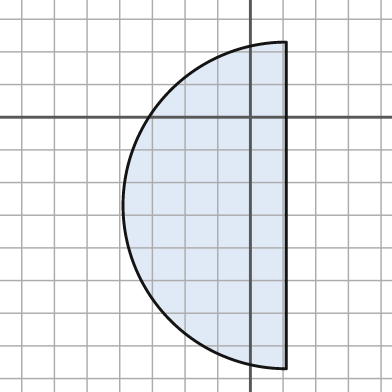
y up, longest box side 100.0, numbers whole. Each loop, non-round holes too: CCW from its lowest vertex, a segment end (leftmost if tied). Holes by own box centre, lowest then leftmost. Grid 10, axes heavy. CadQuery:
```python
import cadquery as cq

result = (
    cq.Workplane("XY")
    .moveTo(11.0, -77.0)
    .lineTo(11.0, 23.0)
    .threePointArc((-39.0, -27.0), (11.0, -77.0))
    .close()
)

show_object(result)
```